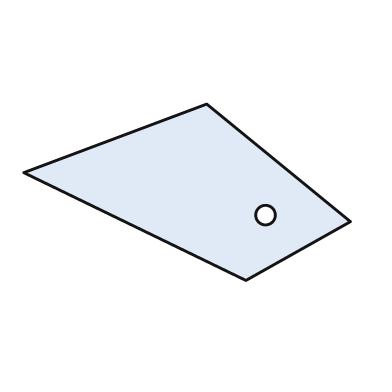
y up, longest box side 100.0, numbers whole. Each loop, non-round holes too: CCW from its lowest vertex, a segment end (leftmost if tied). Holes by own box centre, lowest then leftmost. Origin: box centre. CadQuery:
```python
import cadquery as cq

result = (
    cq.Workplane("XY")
    .moveTo(18.0, -27.0)
    .lineTo(50.0, -9.0)
    .lineTo(6.0, 27.0)
    .lineTo(-50.0, 6.0)
    .close()
    .moveTo(24.0, -7.0)
    .circle(3.0)
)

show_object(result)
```